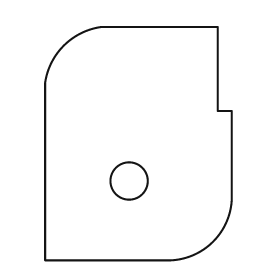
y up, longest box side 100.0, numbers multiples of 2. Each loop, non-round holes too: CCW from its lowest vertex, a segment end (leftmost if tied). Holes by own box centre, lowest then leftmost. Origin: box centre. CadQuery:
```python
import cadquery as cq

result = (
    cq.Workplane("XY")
    .moveTo(-40.0, -50.0)
    .lineTo(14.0, -50.0)
    .threePointArc((32.0, -42.0), (40.0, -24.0))
    .lineTo(40.0, 14.0)
    .lineTo(34.0, 14.0)
    .lineTo(34.0, 50.0)
    .lineTo(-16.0, 50.0)
    .threePointArc((-32.0, 42.0), (-40.0, 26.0))
    .close()
    .moveTo(-4.0, -16.0)
    .circle(8.0)
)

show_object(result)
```